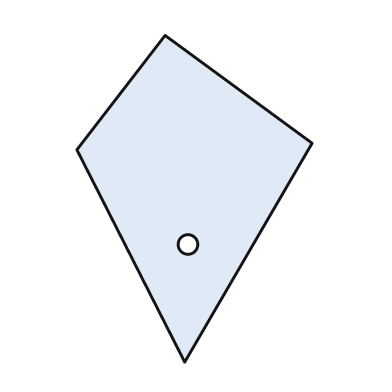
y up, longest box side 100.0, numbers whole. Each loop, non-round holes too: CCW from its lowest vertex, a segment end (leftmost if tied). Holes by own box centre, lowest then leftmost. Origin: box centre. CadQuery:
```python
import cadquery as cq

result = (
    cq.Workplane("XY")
    .moveTo(-3.0, -50.0)
    .lineTo(36.0, 17.0)
    .lineTo(-9.0, 50.0)
    .lineTo(-36.0, 15.0)
    .close()
    .moveTo(-2.0, -14.0)
    .circle(3.0)
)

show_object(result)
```